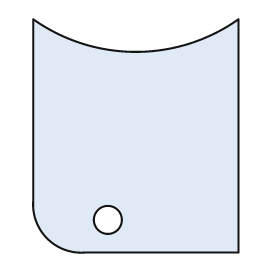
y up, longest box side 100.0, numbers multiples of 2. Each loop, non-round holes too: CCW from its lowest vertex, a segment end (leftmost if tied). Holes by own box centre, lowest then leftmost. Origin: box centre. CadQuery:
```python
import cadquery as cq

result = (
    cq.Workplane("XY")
    .moveTo(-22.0, -50.0)
    .lineTo(44.0, -50.0)
    .lineTo(44.0, 50.0)
    .threePointArc((0.0, 36.0), (-44.0, 50.0))
    .lineTo(-44.0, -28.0)
    .threePointArc((-38.0, -44.0), (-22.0, -50.0))
    .close()
    .moveTo(-12.0, -36.0)
    .circle(6.0)
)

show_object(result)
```